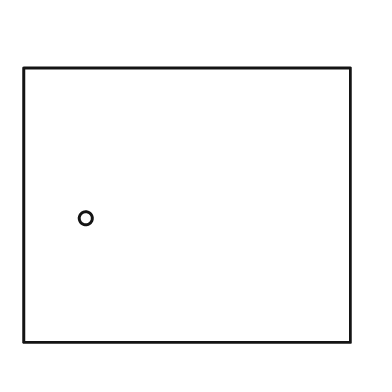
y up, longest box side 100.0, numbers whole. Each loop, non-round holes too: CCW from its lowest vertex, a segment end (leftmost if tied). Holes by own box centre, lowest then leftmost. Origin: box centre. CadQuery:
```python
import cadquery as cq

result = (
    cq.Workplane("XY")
    .moveTo(-50.0, -42.0)
    .lineTo(50.0, -42.0)
    .lineTo(50.0, 42.0)
    .lineTo(-50.0, 42.0)
    .close()
    .moveTo(-31.0, -4.0)
    .circle(2.0)
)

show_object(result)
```